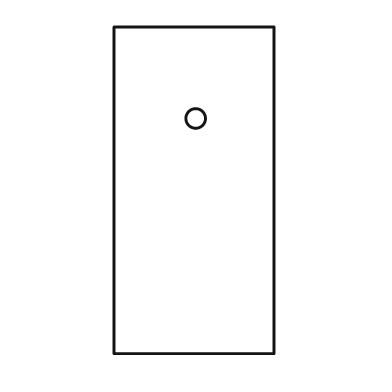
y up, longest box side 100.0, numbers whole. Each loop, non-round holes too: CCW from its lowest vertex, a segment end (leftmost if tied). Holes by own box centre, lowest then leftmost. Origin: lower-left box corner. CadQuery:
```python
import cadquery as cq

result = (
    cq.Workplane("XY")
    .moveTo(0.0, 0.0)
    .lineTo(49.0, 0.0)
    .lineTo(49.0, 100.0)
    .lineTo(0.0, 100.0)
    .close()
    .moveTo(25.0, 72.0)
    .circle(3.0)
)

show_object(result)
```